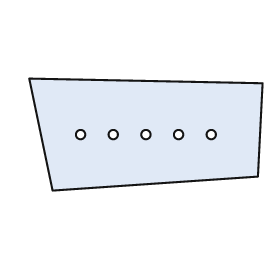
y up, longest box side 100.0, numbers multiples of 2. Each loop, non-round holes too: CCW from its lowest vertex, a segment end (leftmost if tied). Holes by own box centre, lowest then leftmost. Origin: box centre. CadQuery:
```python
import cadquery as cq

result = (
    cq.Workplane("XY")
    .moveTo(-40.0, -24.0)
    .lineTo(48.0, -18.0)
    .lineTo(50.0, 22.0)
    .lineTo(-50.0, 24.0)
    .close()
    .moveTo(-28.0, 0.0)
    .circle(2.0)
    .moveTo(-14.0, 0.0)
    .circle(2.0)
    .moveTo(0.0, 0.0)
    .circle(2.0)
    .moveTo(14.0, 0.0)
    .circle(2.0)
    .moveTo(28.0, 0.0)
    .circle(2.0)
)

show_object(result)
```